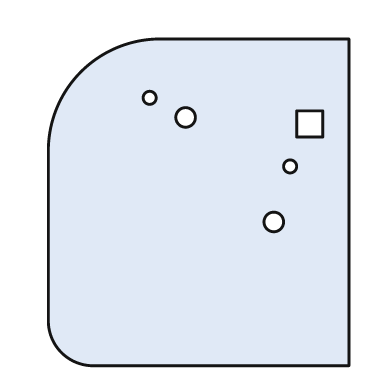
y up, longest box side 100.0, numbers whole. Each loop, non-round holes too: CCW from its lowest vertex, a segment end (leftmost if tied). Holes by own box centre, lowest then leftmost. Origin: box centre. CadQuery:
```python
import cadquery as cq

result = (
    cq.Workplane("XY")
    .moveTo(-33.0, -50.0)
    .lineTo(46.0, -50.0)
    .lineTo(46.0, 50.0)
    .lineTo(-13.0, 50.0)
    .threePointArc((-36.0, 40.0), (-46.0, 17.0))
    .lineTo(-46.0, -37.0)
    .threePointArc((-42.0, -46.0), (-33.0, -50.0))
    .close()
    .moveTo(23.0, -6.0)
    .circle(3.0)
    .moveTo(28.0, 11.0)
    .circle(2.0)
    .moveTo(30.0, 20.0)
    .lineTo(38.0, 20.0)
    .lineTo(38.0, 28.0)
    .lineTo(30.0, 28.0)
    .close()
    .moveTo(-4.0, 26.0)
    .circle(3.0)
    .moveTo(-15.0, 32.0)
    .circle(2.0)
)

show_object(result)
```